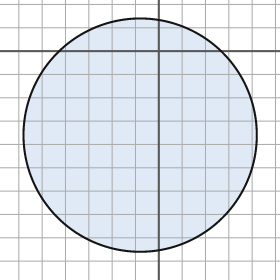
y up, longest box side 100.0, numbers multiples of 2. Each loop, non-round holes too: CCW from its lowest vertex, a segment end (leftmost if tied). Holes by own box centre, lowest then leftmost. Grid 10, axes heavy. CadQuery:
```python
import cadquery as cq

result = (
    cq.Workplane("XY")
    .moveTo(-8.0, -36.0)
    .circle(50.0)
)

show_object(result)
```